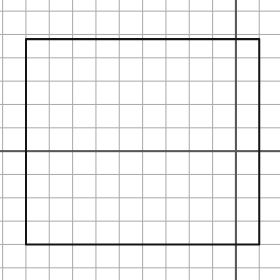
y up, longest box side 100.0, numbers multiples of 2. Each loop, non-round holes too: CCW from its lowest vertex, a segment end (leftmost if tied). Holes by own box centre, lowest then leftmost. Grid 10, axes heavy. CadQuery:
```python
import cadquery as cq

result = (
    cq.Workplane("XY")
    .moveTo(-90.0, -40.0)
    .lineTo(10.0, -40.0)
    .lineTo(10.0, 48.0)
    .lineTo(-90.0, 48.0)
    .close()
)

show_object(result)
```